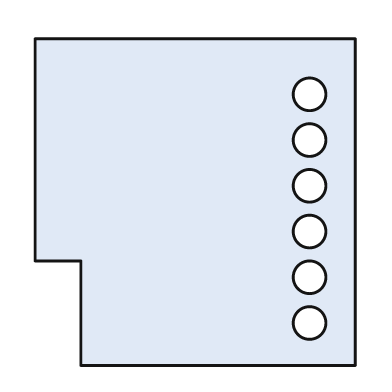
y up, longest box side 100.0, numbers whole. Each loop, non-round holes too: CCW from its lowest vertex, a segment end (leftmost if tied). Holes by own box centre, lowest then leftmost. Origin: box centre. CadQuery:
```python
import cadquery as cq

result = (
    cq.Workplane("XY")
    .moveTo(-35.0, -50.0)
    .lineTo(49.0, -50.0)
    .lineTo(49.0, 50.0)
    .lineTo(-49.0, 50.0)
    .lineTo(-49.0, -18.0)
    .lineTo(-35.0, -18.0)
    .close()
    .moveTo(35.0, -37.0)
    .circle(5.0)
    .moveTo(35.0, -23.0)
    .circle(5.0)
    .moveTo(35.0, -9.0)
    .circle(5.0)
    .moveTo(35.0, 5.0)
    .circle(5.0)
    .moveTo(35.0, 19.0)
    .circle(5.0)
    .moveTo(35.0, 33.0)
    .circle(5.0)
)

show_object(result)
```